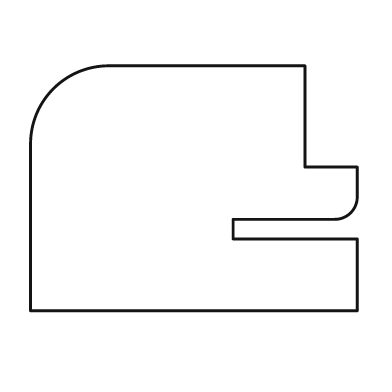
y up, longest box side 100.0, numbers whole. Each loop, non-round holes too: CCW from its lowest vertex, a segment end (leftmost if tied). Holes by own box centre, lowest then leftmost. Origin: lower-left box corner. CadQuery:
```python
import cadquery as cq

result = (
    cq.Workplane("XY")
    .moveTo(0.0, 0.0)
    .lineTo(100.0, 0.0)
    .lineTo(100.0, 22.0)
    .lineTo(62.0, 22.0)
    .lineTo(62.0, 28.0)
    .lineTo(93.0, 28.0)
    .threePointArc((98.0, 30.0), (100.0, 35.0))
    .lineTo(100.0, 44.0)
    .lineTo(84.0, 44.0)
    .lineTo(84.0, 75.0)
    .lineTo(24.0, 75.0)
    .threePointArc((7.0, 68.0), (0.0, 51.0))
    .close()
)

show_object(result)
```